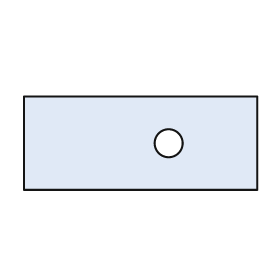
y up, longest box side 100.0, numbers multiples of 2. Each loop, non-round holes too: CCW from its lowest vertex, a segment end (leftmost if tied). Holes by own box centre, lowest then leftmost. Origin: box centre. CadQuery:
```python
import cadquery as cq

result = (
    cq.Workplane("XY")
    .moveTo(-50.0, -20.0)
    .lineTo(50.0, -20.0)
    .lineTo(50.0, 20.0)
    .lineTo(-50.0, 20.0)
    .close()
    .moveTo(12.0, 0.0)
    .circle(6.0)
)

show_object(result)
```